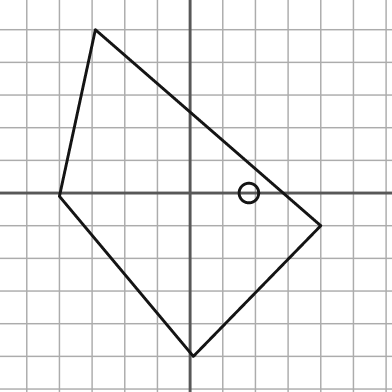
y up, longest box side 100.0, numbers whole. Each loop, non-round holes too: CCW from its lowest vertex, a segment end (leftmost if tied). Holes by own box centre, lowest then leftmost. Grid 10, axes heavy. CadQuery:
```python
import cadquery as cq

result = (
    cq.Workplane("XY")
    .moveTo(1.0, -50.0)
    .lineTo(40.0, -10.0)
    .lineTo(-29.0, 50.0)
    .lineTo(-40.0, -1.0)
    .close()
    .moveTo(18.0, 0.0)
    .circle(3.0)
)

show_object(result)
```